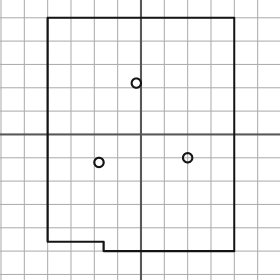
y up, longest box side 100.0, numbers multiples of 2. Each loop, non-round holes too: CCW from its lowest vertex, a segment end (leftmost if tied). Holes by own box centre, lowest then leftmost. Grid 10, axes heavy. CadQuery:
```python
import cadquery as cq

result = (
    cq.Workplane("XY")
    .moveTo(-16.0, -50.0)
    .lineTo(40.0, -50.0)
    .lineTo(40.0, 50.0)
    .lineTo(-40.0, 50.0)
    .lineTo(-40.0, -46.0)
    .lineTo(-16.0, -46.0)
    .close()
    .moveTo(-18.0, -12.0)
    .circle(2.0)
    .moveTo(20.0, -10.0)
    .circle(2.0)
    .moveTo(-2.0, 22.0)
    .circle(2.0)
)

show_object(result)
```